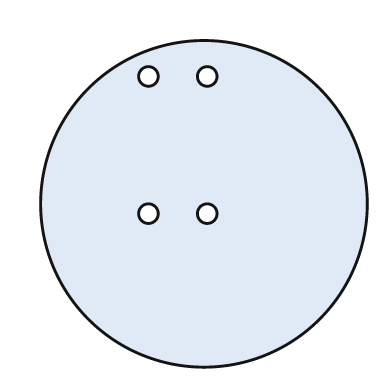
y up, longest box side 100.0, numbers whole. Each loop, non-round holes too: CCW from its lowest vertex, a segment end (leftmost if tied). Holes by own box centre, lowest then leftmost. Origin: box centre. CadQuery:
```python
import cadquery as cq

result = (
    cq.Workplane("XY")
    .moveTo(0.0, 0.0)
    .circle(50.0)
    .moveTo(-17.0, -3.0)
    .circle(3.0)
    .moveTo(1.0, -3.0)
    .circle(3.0)
    .moveTo(-17.0, 39.0)
    .circle(3.0)
    .moveTo(1.0, 39.0)
    .circle(3.0)
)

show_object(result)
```